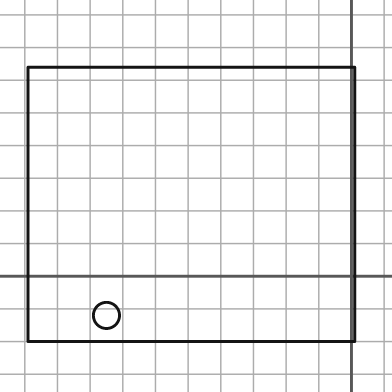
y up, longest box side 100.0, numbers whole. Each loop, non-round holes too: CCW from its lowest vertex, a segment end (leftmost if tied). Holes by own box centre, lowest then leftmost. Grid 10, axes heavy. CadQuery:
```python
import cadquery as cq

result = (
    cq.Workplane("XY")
    .moveTo(-99.0, -20.0)
    .lineTo(1.0, -20.0)
    .lineTo(1.0, 64.0)
    .lineTo(-99.0, 64.0)
    .close()
    .moveTo(-75.0, -12.0)
    .circle(4.0)
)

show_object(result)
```